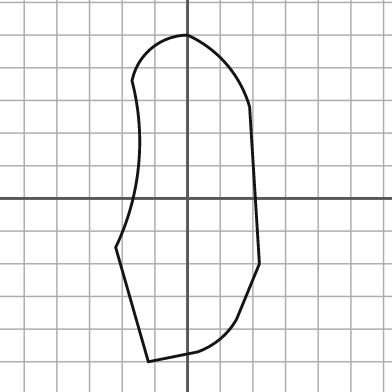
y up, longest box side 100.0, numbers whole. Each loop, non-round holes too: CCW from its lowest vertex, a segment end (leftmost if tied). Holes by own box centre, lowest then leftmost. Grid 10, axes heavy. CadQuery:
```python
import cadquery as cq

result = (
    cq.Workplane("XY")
    .moveTo(-12.0, -50.0)
    .lineTo(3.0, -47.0)
    .threePointArc((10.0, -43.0), (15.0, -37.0))
    .lineTo(22.0, -20.0)
    .lineTo(19.0, 28.0)
    .threePointArc((12.0, 41.0), (0.0, 50.0))
    .threePointArc((-11.0, 46.0), (-17.0, 36.0))
    .threePointArc((-15.0, 10.0), (-22.0, -15.0))
    .close()
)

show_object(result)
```